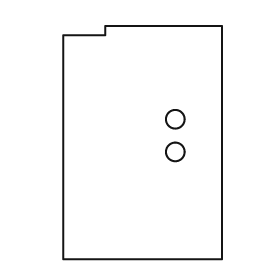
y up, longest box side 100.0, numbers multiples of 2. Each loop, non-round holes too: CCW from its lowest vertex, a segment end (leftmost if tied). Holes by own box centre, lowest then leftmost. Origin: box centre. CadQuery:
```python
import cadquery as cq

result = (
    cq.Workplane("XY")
    .moveTo(-34.0, -50.0)
    .lineTo(34.0, -50.0)
    .lineTo(34.0, 50.0)
    .lineTo(-16.0, 50.0)
    .lineTo(-16.0, 46.0)
    .lineTo(-34.0, 46.0)
    .close()
    .moveTo(14.0, -4.0)
    .circle(4.0)
    .moveTo(14.0, 10.0)
    .circle(4.0)
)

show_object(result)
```